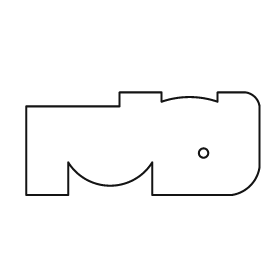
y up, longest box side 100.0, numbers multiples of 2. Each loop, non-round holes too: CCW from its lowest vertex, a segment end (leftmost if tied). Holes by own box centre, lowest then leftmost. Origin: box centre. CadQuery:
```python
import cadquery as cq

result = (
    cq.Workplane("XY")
    .moveTo(-50.0, -22.0)
    .lineTo(-32.0, -22.0)
    .lineTo(-32.0, -8.0)
    .threePointArc((-14.0, -18.0), (4.0, -8.0))
    .lineTo(4.0, -22.0)
    .lineTo(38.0, -22.0)
    .threePointArc((46.0, -18.0), (50.0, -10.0))
    .lineTo(50.0, 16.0)
    .threePointArc((48.0, 20.0), (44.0, 22.0))
    .lineTo(32.0, 22.0)
    .lineTo(32.0, 18.0)
    .threePointArc((20.0, 20.0), (8.0, 18.0))
    .lineTo(8.0, 22.0)
    .lineTo(-10.0, 22.0)
    .lineTo(-10.0, 16.0)
    .lineTo(-50.0, 16.0)
    .close()
    .moveTo(26.0, -4.0)
    .circle(2.0)
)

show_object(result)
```